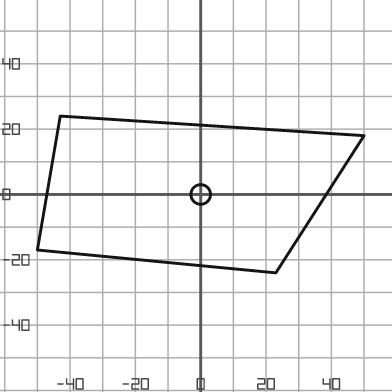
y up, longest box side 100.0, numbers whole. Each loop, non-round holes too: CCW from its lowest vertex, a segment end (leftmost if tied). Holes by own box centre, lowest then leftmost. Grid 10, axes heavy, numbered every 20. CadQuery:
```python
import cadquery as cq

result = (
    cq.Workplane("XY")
    .moveTo(23.0, -24.0)
    .lineTo(50.0, 18.0)
    .lineTo(-43.0, 24.0)
    .lineTo(-50.0, -17.0)
    .close()
    .moveTo(0.0, 0.0)
    .circle(3.0)
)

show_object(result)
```